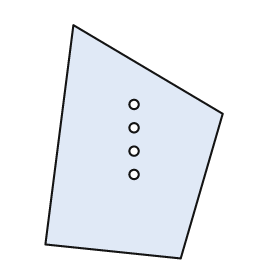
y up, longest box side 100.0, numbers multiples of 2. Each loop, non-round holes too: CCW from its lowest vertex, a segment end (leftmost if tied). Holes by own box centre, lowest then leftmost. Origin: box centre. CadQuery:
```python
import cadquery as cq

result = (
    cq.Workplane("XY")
    .moveTo(20.0, -50.0)
    .lineTo(38.0, 12.0)
    .lineTo(-26.0, 50.0)
    .lineTo(-38.0, -44.0)
    .close()
    .moveTo(0.0, -14.0)
    .circle(2.0)
    .moveTo(0.0, -4.0)
    .circle(2.0)
    .moveTo(0.0, 6.0)
    .circle(2.0)
    .moveTo(0.0, 16.0)
    .circle(2.0)
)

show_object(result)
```